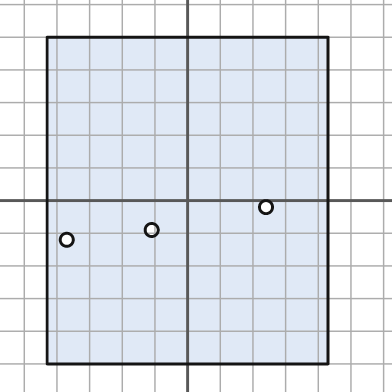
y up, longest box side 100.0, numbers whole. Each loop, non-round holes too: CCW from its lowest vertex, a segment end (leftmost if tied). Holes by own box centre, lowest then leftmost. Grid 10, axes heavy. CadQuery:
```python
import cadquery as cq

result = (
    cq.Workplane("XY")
    .moveTo(-43.0, -50.0)
    .lineTo(43.0, -50.0)
    .lineTo(43.0, 50.0)
    .lineTo(-43.0, 50.0)
    .close()
    .moveTo(-37.0, -12.0)
    .circle(2.0)
    .moveTo(-11.0, -9.0)
    .circle(2.0)
    .moveTo(24.0, -2.0)
    .circle(2.0)
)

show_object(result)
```